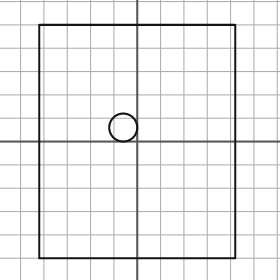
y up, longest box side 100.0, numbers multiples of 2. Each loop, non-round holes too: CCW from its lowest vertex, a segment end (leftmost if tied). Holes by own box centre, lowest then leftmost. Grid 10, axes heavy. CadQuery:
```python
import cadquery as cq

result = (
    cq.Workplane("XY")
    .moveTo(-42.0, -50.0)
    .lineTo(42.0, -50.0)
    .lineTo(42.0, 50.0)
    .lineTo(-42.0, 50.0)
    .close()
    .moveTo(-6.0, 6.0)
    .circle(6.0)
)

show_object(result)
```